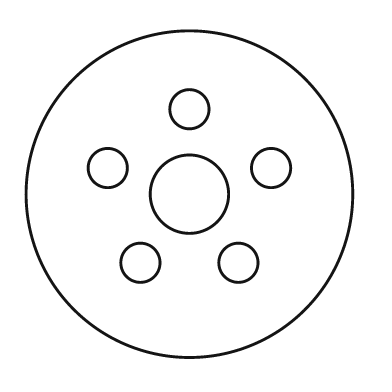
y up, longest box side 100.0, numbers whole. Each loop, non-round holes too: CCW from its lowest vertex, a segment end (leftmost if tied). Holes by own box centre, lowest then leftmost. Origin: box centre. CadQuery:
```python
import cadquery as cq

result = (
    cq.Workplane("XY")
    .moveTo(0.0, 0.0)
    .circle(50.0)
    .moveTo(-15.0, -21.0)
    .circle(6.0)
    .moveTo(15.0, -21.0)
    .circle(6.0)
    .moveTo(0.0, 0.0)
    .circle(12.0)
    .moveTo(-25.0, 8.0)
    .circle(6.0)
    .moveTo(25.0, 8.0)
    .circle(6.0)
    .moveTo(0.0, 26.0)
    .circle(6.0)
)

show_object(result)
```